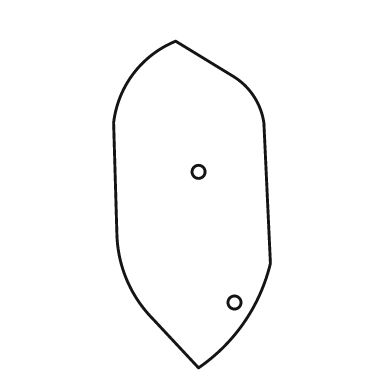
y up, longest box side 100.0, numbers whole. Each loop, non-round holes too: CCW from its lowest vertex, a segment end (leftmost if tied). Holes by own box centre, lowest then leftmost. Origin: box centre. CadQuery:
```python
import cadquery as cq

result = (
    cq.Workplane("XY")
    .moveTo(2.0, -50.0)
    .threePointArc((16.0, -36.0), (24.0, -18.0))
    .lineTo(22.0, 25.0)
    .threePointArc((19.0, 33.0), (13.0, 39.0))
    .lineTo(-5.0, 50.0)
    .threePointArc((-18.0, 40.0), (-24.0, 25.0))
    .lineTo(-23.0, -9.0)
    .threePointArc((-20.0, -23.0), (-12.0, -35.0))
    .close()
    .moveTo(13.0, -30.0)
    .circle(2.0)
    .moveTo(2.0, 10.0)
    .circle(2.0)
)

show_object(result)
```